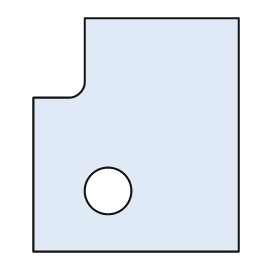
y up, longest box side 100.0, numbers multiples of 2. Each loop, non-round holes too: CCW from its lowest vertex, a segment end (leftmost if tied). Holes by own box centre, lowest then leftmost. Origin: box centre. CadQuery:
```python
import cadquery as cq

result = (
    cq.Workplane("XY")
    .moveTo(-44.0, -50.0)
    .lineTo(44.0, -50.0)
    .lineTo(44.0, 50.0)
    .lineTo(-22.0, 50.0)
    .lineTo(-22.0, 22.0)
    .threePointArc((-24.0, 18.0), (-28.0, 16.0))
    .lineTo(-44.0, 16.0)
    .close()
    .moveTo(-12.0, -24.0)
    .circle(10.0)
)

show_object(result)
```